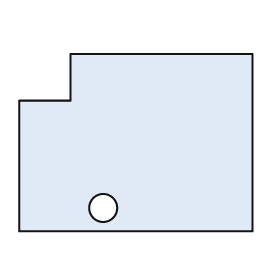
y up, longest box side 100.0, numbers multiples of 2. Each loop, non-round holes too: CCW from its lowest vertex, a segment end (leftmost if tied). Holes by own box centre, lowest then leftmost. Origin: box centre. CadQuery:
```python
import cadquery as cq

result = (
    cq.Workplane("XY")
    .moveTo(-50.0, -38.0)
    .lineTo(50.0, -38.0)
    .lineTo(50.0, 38.0)
    .lineTo(-28.0, 38.0)
    .lineTo(-28.0, 18.0)
    .lineTo(-50.0, 18.0)
    .close()
    .moveTo(-14.0, -28.0)
    .circle(6.0)
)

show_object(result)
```